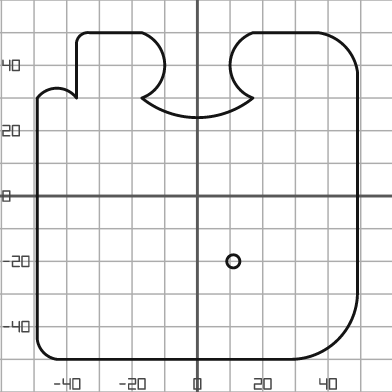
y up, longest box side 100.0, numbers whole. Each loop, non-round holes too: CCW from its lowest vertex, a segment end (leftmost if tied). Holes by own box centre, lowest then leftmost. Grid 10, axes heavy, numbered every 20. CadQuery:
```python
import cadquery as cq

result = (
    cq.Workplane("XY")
    .moveTo(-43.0, -50.0)
    .lineTo(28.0, -50.0)
    .threePointArc((43.0, -44.0), (49.0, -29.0))
    .lineTo(49.0, 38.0)
    .threePointArc((45.0, 46.0), (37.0, 50.0))
    .lineTo(17.0, 50.0)
    .threePointArc((10.0, 40.0), (17.0, 30.0))
    .threePointArc((0.0, 24.0), (-17.0, 30.0))
    .threePointArc((-10.0, 40.0), (-17.0, 50.0))
    .lineTo(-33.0, 50.0)
    .threePointArc((-36.0, 49.0), (-37.0, 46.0))
    .lineTo(-37.0, 30.0)
    .threePointArc((-43.0, 33.0), (-49.0, 30.0))
    .lineTo(-49.0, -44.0)
    .threePointArc((-47.0, -48.0), (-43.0, -50.0))
    .close()
    .moveTo(11.0, -20.0)
    .circle(2.0)
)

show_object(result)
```